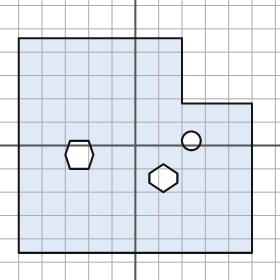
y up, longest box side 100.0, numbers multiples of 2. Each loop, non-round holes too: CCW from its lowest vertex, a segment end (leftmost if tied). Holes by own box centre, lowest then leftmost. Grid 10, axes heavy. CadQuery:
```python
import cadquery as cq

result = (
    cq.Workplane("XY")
    .moveTo(-50.0, -46.0)
    .lineTo(50.0, -46.0)
    .lineTo(50.0, 18.0)
    .lineTo(20.0, 18.0)
    .lineTo(20.0, 46.0)
    .lineTo(-50.0, 46.0)
    .close()
    .moveTo(12.0, -20.0)
    .lineTo(18.0, -16.0)
    .lineTo(18.0, -12.0)
    .lineTo(12.0, -8.0)
    .lineTo(6.0, -12.0)
    .lineTo(6.0, -16.0)
    .close()
    .moveTo(-28.0, -10.0)
    .lineTo(-20.0, -10.0)
    .lineTo(-18.0, -4.0)
    .lineTo(-20.0, 2.0)
    .lineTo(-28.0, 2.0)
    .lineTo(-30.0, -4.0)
    .close()
    .moveTo(24.0, 2.0)
    .circle(4.0)
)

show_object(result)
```